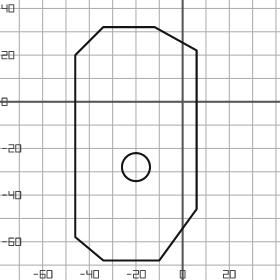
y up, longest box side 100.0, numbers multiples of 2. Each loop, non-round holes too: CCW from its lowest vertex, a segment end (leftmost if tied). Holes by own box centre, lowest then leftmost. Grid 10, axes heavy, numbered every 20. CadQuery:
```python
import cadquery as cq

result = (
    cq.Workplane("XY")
    .moveTo(-34.0, -68.0)
    .lineTo(-10.0, -68.0)
    .lineTo(6.0, -46.0)
    .lineTo(6.0, 22.0)
    .lineTo(-12.0, 32.0)
    .lineTo(-34.0, 32.0)
    .lineTo(-46.0, 20.0)
    .lineTo(-46.0, -58.0)
    .close()
    .moveTo(-20.0, -28.0)
    .circle(6.0)
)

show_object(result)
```